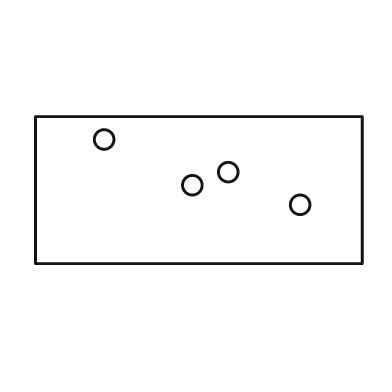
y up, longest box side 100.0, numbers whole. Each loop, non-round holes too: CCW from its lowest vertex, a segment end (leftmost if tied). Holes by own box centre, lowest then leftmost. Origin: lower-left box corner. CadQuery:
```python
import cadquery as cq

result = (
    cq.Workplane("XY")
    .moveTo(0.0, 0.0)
    .lineTo(100.0, 0.0)
    .lineTo(100.0, 45.0)
    .lineTo(0.0, 45.0)
    .close()
    .moveTo(81.0, 18.0)
    .circle(3.0)
    .moveTo(48.0, 24.0)
    .circle(3.0)
    .moveTo(59.0, 28.0)
    .circle(3.0)
    .moveTo(21.0, 38.0)
    .circle(3.0)
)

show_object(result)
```